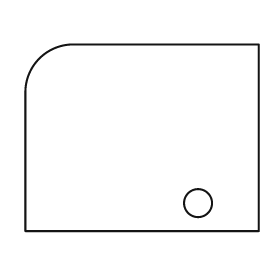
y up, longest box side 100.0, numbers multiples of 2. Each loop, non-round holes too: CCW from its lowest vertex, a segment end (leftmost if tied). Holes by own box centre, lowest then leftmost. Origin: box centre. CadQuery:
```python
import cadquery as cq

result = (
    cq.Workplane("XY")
    .moveTo(-50.0, -40.0)
    .lineTo(50.0, -40.0)
    .lineTo(50.0, 40.0)
    .lineTo(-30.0, 40.0)
    .threePointArc((-44.0, 34.0), (-50.0, 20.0))
    .close()
    .moveTo(24.0, -28.0)
    .circle(6.0)
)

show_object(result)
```